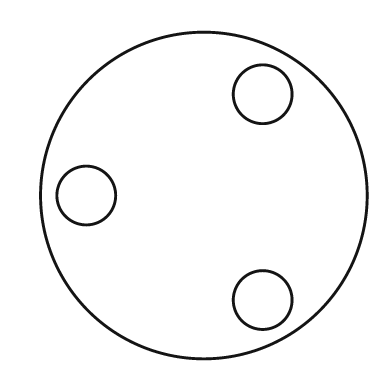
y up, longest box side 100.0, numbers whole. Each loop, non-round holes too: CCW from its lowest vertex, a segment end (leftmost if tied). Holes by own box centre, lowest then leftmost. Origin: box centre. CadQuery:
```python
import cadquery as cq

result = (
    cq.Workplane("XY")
    .moveTo(0.0, 0.0)
    .circle(50.0)
    .moveTo(18.0, -32.0)
    .circle(9.0)
    .moveTo(-36.0, 0.0)
    .circle(9.0)
    .moveTo(18.0, 31.0)
    .circle(9.0)
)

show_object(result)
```